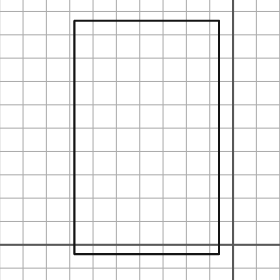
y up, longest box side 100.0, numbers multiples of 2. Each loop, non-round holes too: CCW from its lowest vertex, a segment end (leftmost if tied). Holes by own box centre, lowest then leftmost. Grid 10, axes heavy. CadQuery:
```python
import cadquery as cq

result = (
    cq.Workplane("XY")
    .moveTo(-68.0, -4.0)
    .lineTo(-6.0, -4.0)
    .lineTo(-6.0, 96.0)
    .lineTo(-68.0, 96.0)
    .close()
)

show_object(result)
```